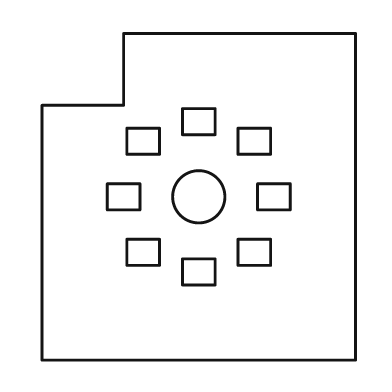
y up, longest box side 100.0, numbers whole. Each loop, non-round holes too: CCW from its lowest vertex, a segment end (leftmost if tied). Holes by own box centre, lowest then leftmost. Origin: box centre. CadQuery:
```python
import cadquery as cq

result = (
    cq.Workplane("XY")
    .moveTo(-48.0, -50.0)
    .lineTo(48.0, -50.0)
    .lineTo(48.0, 50.0)
    .lineTo(-23.0, 50.0)
    .lineTo(-23.0, 28.0)
    .lineTo(-48.0, 28.0)
    .close()
    .moveTo(-5.0, -27.0)
    .lineTo(5.0, -27.0)
    .lineTo(5.0, -19.0)
    .lineTo(-5.0, -19.0)
    .close()
    .moveTo(-22.0, -21.0)
    .lineTo(-12.0, -21.0)
    .lineTo(-12.0, -13.0)
    .lineTo(-22.0, -13.0)
    .close()
    .moveTo(12.0, -21.0)
    .lineTo(22.0, -21.0)
    .lineTo(22.0, -13.0)
    .lineTo(12.0, -13.0)
    .close()
    .moveTo(-28.0, -4.0)
    .lineTo(-18.0, -4.0)
    .lineTo(-18.0, 4.0)
    .lineTo(-28.0, 4.0)
    .close()
    .moveTo(0.0, 0.0)
    .circle(8.0)
    .moveTo(18.0, -4.0)
    .lineTo(28.0, -4.0)
    .lineTo(28.0, 4.0)
    .lineTo(18.0, 4.0)
    .close()
    .moveTo(-22.0, 13.0)
    .lineTo(-12.0, 13.0)
    .lineTo(-12.0, 21.0)
    .lineTo(-22.0, 21.0)
    .close()
    .moveTo(12.0, 13.0)
    .lineTo(22.0, 13.0)
    .lineTo(22.0, 21.0)
    .lineTo(12.0, 21.0)
    .close()
    .moveTo(-5.0, 19.0)
    .lineTo(5.0, 19.0)
    .lineTo(5.0, 27.0)
    .lineTo(-5.0, 27.0)
    .close()
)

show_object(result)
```